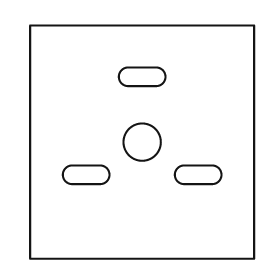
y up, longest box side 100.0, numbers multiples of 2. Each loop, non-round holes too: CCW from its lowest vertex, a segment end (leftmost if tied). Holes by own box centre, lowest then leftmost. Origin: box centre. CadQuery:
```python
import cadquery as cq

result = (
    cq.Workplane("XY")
    .moveTo(-48.0, -50.0)
    .lineTo(48.0, -50.0)
    .lineTo(48.0, 50.0)
    .lineTo(-48.0, 50.0)
    .close()
    .moveTo(-30.0, -18.0)
    .lineTo(-18.0, -18.0)
    .threePointArc((-14.0, -14.0), (-18.0, -10.0))
    .lineTo(-30.0, -10.0)
    .threePointArc((-34.0, -14.0), (-30.0, -18.0))
    .close()
    .moveTo(18.0, -18.0)
    .lineTo(30.0, -18.0)
    .threePointArc((34.0, -14.0), (30.0, -10.0))
    .lineTo(18.0, -10.0)
    .threePointArc((14.0, -14.0), (18.0, -18.0))
    .close()
    .moveTo(0.0, 0.0)
    .circle(8.0)
    .moveTo(-6.0, 24.0)
    .lineTo(6.0, 24.0)
    .threePointArc((10.0, 28.0), (6.0, 32.0))
    .lineTo(-6.0, 32.0)
    .threePointArc((-10.0, 28.0), (-6.0, 24.0))
    .close()
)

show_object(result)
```